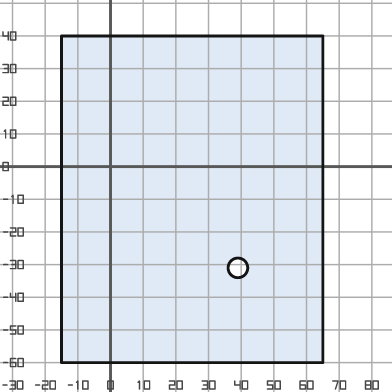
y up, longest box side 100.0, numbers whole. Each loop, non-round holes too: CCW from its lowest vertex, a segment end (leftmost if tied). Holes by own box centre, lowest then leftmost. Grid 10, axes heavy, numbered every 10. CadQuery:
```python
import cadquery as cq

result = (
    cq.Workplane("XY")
    .moveTo(-15.0, -60.0)
    .lineTo(65.0, -60.0)
    .lineTo(65.0, 40.0)
    .lineTo(-15.0, 40.0)
    .close()
    .moveTo(39.0, -31.0)
    .circle(3.0)
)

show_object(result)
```